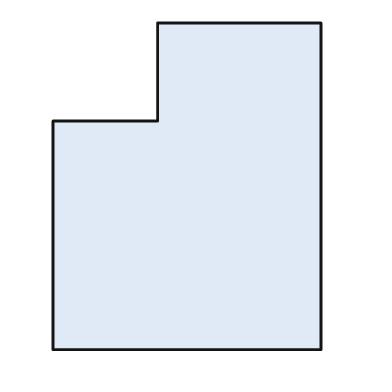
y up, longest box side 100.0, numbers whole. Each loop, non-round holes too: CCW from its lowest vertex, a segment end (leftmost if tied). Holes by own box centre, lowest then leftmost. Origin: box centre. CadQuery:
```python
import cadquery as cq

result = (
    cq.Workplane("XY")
    .moveTo(-41.0, -50.0)
    .lineTo(41.0, -50.0)
    .lineTo(41.0, 50.0)
    .lineTo(-9.0, 50.0)
    .lineTo(-9.0, 20.0)
    .lineTo(-41.0, 20.0)
    .close()
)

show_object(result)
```